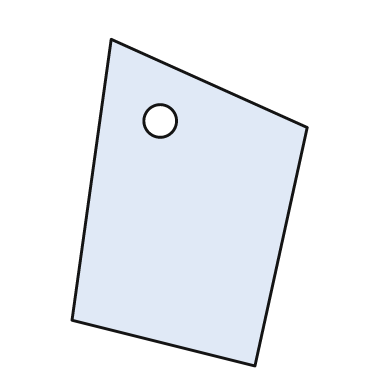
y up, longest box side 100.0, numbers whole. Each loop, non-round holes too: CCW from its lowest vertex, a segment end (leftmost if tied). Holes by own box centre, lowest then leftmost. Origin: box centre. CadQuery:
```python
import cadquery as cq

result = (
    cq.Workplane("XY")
    .moveTo(20.0, -50.0)
    .lineTo(36.0, 23.0)
    .lineTo(-24.0, 50.0)
    .lineTo(-36.0, -36.0)
    .close()
    .moveTo(-9.0, 25.0)
    .circle(5.0)
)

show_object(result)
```